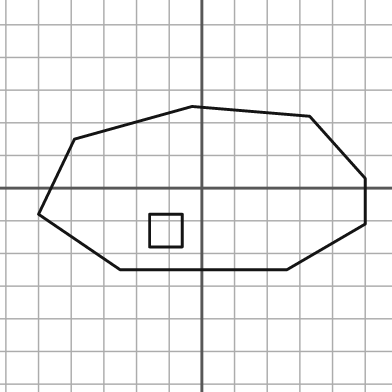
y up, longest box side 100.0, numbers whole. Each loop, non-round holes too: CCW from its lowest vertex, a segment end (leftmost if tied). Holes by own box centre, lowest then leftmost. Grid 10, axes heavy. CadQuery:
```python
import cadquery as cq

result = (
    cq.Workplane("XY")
    .moveTo(-25.0, -25.0)
    .lineTo(26.0, -25.0)
    .lineTo(50.0, -11.0)
    .lineTo(50.0, 3.0)
    .lineTo(33.0, 22.0)
    .lineTo(-3.0, 25.0)
    .lineTo(-39.0, 15.0)
    .lineTo(-50.0, -8.0)
    .close()
    .moveTo(-16.0, -18.0)
    .lineTo(-6.0, -18.0)
    .lineTo(-6.0, -8.0)
    .lineTo(-16.0, -8.0)
    .close()
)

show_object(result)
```